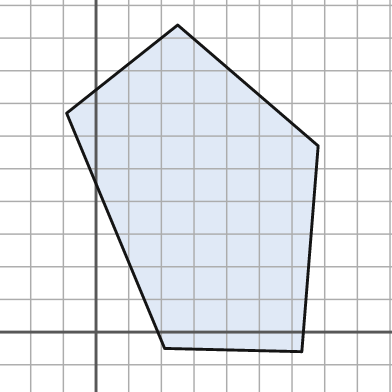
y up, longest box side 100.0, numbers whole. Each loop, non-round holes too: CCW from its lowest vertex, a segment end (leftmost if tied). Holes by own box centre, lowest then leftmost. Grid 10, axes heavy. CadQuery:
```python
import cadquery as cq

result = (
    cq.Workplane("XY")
    .moveTo(63.0, -6.0)
    .lineTo(68.0, 57.0)
    .lineTo(25.0, 94.0)
    .lineTo(-9.0, 67.0)
    .lineTo(21.0, -5.0)
    .close()
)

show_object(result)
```